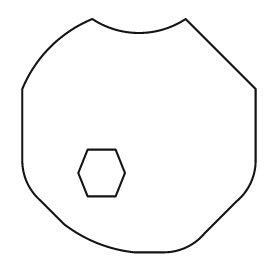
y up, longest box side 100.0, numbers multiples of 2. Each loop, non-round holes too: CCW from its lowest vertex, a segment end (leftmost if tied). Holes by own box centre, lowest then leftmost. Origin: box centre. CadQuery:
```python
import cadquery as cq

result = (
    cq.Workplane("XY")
    .moveTo(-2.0, -50.0)
    .lineTo(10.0, -50.0)
    .threePointArc((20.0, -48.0), (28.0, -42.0))
    .lineTo(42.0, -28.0)
    .threePointArc((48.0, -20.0), (50.0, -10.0))
    .lineTo(50.0, 20.0)
    .lineTo(20.0, 50.0)
    .threePointArc((0.0, 44.0), (-20.0, 50.0))
    .threePointArc((-38.0, 38.0), (-50.0, 20.0))
    .lineTo(-50.0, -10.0)
    .threePointArc((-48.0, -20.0), (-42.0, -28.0))
    .lineTo(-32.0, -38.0)
    .threePointArc((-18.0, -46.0), (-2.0, -50.0))
    .close()
    .moveTo(-22.0, -26.0)
    .lineTo(-10.0, -26.0)
    .lineTo(-6.0, -16.0)
    .lineTo(-10.0, -6.0)
    .lineTo(-22.0, -6.0)
    .lineTo(-26.0, -16.0)
    .close()
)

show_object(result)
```